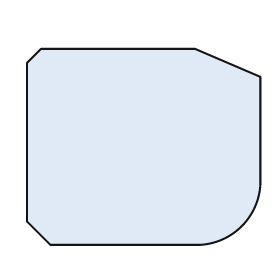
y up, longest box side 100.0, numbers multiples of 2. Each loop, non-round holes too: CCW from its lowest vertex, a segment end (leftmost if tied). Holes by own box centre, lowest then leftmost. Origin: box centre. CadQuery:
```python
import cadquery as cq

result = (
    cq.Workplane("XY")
    .moveTo(-40.0, -42.0)
    .lineTo(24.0, -42.0)
    .threePointArc((42.0, -34.0), (50.0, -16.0))
    .lineTo(50.0, 30.0)
    .lineTo(22.0, 42.0)
    .lineTo(-44.0, 42.0)
    .lineTo(-50.0, 36.0)
    .lineTo(-50.0, -32.0)
    .close()
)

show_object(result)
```